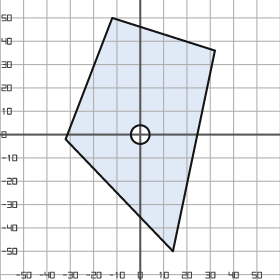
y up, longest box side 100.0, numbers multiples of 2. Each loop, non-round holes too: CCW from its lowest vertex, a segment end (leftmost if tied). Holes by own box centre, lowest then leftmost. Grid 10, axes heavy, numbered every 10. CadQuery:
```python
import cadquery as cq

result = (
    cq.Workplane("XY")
    .moveTo(14.0, -50.0)
    .lineTo(32.0, 36.0)
    .lineTo(-12.0, 50.0)
    .lineTo(-32.0, -2.0)
    .close()
    .moveTo(0.0, 0.0)
    .circle(4.0)
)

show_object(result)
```